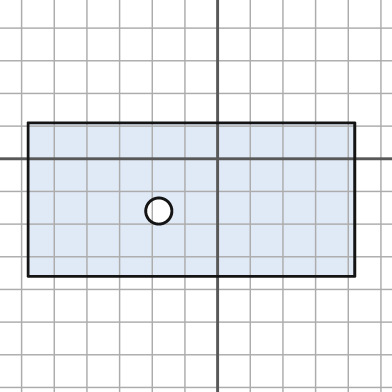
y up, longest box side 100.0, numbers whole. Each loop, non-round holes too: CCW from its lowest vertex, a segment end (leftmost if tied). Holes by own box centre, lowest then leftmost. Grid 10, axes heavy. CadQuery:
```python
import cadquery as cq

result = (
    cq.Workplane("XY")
    .moveTo(-58.0, -36.0)
    .lineTo(42.0, -36.0)
    .lineTo(42.0, 11.0)
    .lineTo(-58.0, 11.0)
    .close()
    .moveTo(-18.0, -16.0)
    .circle(4.0)
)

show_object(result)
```